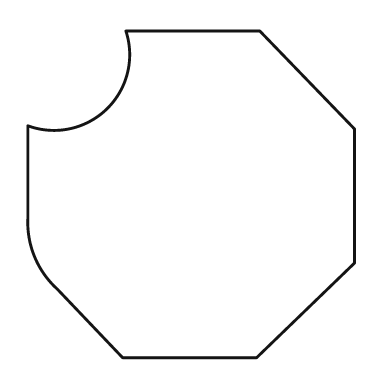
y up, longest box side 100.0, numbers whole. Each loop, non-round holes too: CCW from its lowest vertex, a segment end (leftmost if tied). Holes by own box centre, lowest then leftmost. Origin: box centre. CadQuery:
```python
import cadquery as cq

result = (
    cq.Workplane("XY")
    .moveTo(-21.0, -50.0)
    .lineTo(20.0, -50.0)
    .lineTo(50.0, -21.0)
    .lineTo(50.0, 20.0)
    .lineTo(21.0, 50.0)
    .lineTo(-20.0, 50.0)
    .threePointArc((-26.0, 26.0), (-50.0, 21.0))
    .lineTo(-50.0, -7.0)
    .threePointArc((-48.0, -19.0), (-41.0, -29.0))
    .close()
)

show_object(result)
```